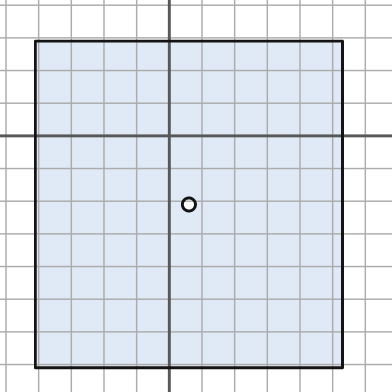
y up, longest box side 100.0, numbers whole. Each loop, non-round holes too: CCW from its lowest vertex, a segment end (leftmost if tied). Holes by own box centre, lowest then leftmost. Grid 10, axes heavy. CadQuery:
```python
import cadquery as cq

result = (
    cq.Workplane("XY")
    .moveTo(-41.0, -71.0)
    .lineTo(53.0, -71.0)
    .lineTo(53.0, 29.0)
    .lineTo(-41.0, 29.0)
    .close()
    .moveTo(6.0, -21.0)
    .circle(2.0)
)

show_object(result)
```